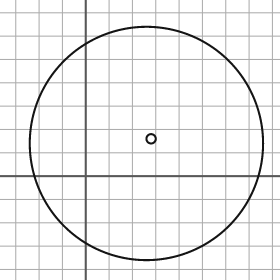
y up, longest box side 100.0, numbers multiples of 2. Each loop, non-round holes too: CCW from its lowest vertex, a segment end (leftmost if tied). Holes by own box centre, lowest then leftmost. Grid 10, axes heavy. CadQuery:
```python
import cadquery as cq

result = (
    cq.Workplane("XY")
    .moveTo(26.0, 14.0)
    .circle(50.0)
    .moveTo(28.0, 16.0)
    .circle(2.0)
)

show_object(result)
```